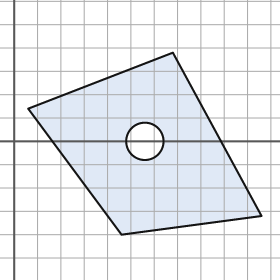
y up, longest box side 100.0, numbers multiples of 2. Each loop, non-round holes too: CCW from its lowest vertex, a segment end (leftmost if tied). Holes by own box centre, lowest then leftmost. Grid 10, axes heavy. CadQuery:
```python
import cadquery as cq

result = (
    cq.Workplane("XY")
    .moveTo(46.0, -40.0)
    .lineTo(106.0, -32.0)
    .lineTo(68.0, 38.0)
    .lineTo(6.0, 14.0)
    .close()
    .moveTo(56.0, 0.0)
    .circle(8.0)
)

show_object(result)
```